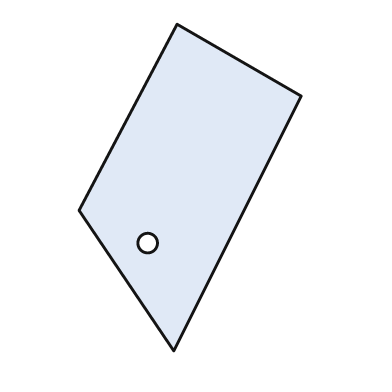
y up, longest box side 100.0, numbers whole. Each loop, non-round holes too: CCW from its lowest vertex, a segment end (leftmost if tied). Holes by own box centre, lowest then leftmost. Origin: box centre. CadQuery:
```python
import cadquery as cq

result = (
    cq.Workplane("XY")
    .moveTo(-5.0, -50.0)
    .lineTo(34.0, 28.0)
    .lineTo(-4.0, 50.0)
    .lineTo(-34.0, -7.0)
    .close()
    .moveTo(-13.0, -17.0)
    .circle(3.0)
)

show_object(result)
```